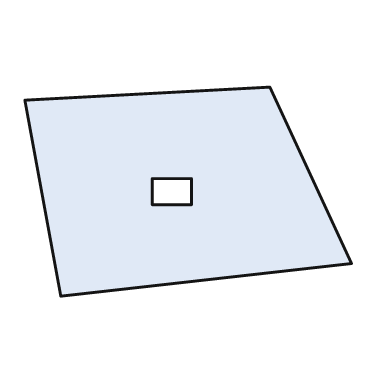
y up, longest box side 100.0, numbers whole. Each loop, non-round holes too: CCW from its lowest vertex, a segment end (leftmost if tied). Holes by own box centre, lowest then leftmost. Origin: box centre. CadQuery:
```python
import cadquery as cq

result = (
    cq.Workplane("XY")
    .moveTo(-39.0, -32.0)
    .lineTo(50.0, -22.0)
    .lineTo(25.0, 32.0)
    .lineTo(-50.0, 28.0)
    .close()
    .moveTo(-11.0, -4.0)
    .lineTo(1.0, -4.0)
    .lineTo(1.0, 4.0)
    .lineTo(-11.0, 4.0)
    .close()
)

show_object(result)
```